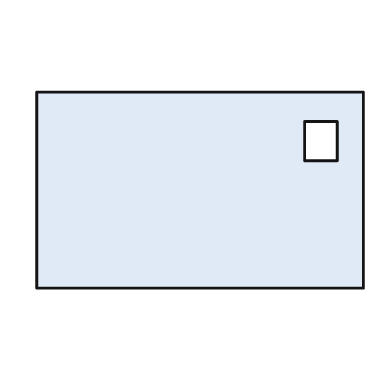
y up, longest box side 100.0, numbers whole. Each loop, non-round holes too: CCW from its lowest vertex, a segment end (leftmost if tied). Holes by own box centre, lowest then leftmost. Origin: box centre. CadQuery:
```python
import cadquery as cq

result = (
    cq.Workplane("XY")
    .moveTo(-50.0, -30.0)
    .lineTo(50.0, -30.0)
    .lineTo(50.0, 30.0)
    .lineTo(-50.0, 30.0)
    .close()
    .moveTo(32.0, 9.0)
    .lineTo(42.0, 9.0)
    .lineTo(42.0, 21.0)
    .lineTo(32.0, 21.0)
    .close()
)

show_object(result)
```